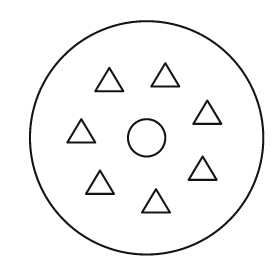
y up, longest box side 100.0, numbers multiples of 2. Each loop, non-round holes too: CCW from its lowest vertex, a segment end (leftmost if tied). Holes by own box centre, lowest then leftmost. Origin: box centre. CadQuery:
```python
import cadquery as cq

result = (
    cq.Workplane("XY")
    .moveTo(0.0, 0.0)
    .circle(50.0)
    .moveTo(-2.0, -32.0)
    .lineTo(10.0, -32.0)
    .lineTo(4.0, -22.0)
    .close()
    .moveTo(-26.0, -24.0)
    .lineTo(-14.0, -24.0)
    .lineTo(-20.0, -14.0)
    .close()
    .moveTo(18.0, -18.0)
    .lineTo(30.0, -18.0)
    .lineTo(24.0, -8.0)
    .close()
    .moveTo(0.0, 0.0)
    .circle(8.0)
    .moveTo(-34.0, -2.0)
    .lineTo(-22.0, -2.0)
    .lineTo(-28.0, 8.0)
    .close()
    .moveTo(20.0, 6.0)
    .lineTo(32.0, 6.0)
    .lineTo(26.0, 16.0)
    .close()
    .moveTo(-22.0, 20.0)
    .lineTo(-10.0, 20.0)
    .lineTo(-16.0, 30.0)
    .close()
    .moveTo(2.0, 22.0)
    .lineTo(14.0, 22.0)
    .lineTo(8.0, 32.0)
    .close()
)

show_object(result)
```